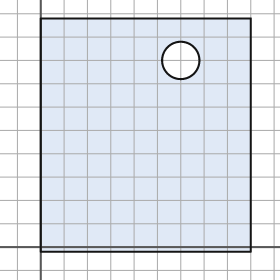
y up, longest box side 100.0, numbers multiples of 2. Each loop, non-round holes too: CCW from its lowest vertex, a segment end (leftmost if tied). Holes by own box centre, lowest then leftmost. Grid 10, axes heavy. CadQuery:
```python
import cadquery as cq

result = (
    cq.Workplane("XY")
    .moveTo(0.0, -2.0)
    .lineTo(90.0, -2.0)
    .lineTo(90.0, 98.0)
    .lineTo(0.0, 98.0)
    .close()
    .moveTo(60.0, 80.0)
    .circle(8.0)
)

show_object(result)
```